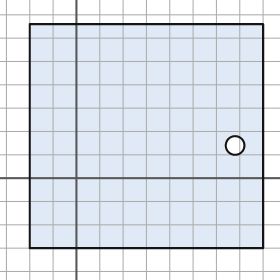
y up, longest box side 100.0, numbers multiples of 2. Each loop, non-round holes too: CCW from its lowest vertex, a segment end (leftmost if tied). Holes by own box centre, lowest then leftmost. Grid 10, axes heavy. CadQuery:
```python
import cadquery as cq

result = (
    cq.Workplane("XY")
    .moveTo(-20.0, -30.0)
    .lineTo(80.0, -30.0)
    .lineTo(80.0, 66.0)
    .lineTo(-20.0, 66.0)
    .close()
    .moveTo(68.0, 14.0)
    .circle(4.0)
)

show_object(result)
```